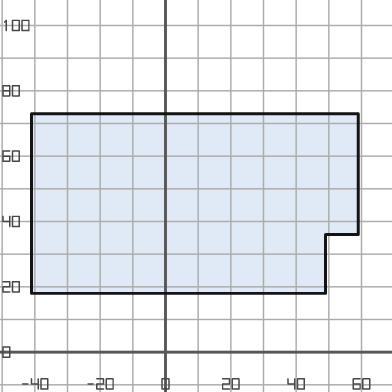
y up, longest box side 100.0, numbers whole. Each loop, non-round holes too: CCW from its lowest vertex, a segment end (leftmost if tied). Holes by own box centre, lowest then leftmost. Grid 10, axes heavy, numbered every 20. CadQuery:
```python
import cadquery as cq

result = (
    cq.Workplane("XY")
    .moveTo(-41.0, 18.0)
    .lineTo(49.0, 18.0)
    .lineTo(49.0, 36.0)
    .lineTo(59.0, 36.0)
    .lineTo(59.0, 73.0)
    .lineTo(-41.0, 73.0)
    .close()
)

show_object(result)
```